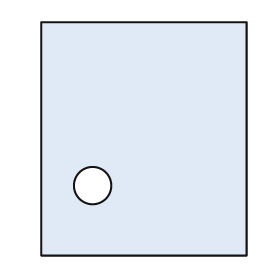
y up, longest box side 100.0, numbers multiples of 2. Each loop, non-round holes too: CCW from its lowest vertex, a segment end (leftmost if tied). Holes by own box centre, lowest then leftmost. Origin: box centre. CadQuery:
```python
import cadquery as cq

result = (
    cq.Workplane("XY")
    .moveTo(-44.0, -50.0)
    .lineTo(44.0, -50.0)
    .lineTo(44.0, 50.0)
    .lineTo(-44.0, 50.0)
    .close()
    .moveTo(-22.0, -20.0)
    .circle(8.0)
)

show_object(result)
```